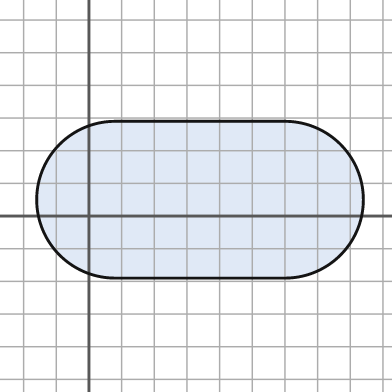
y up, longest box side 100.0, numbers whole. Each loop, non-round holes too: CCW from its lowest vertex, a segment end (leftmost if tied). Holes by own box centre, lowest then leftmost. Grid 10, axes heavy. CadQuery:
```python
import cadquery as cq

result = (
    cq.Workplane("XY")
    .moveTo(8.0, -19.0)
    .lineTo(60.0, -19.0)
    .threePointArc((84.0, 5.0), (60.0, 29.0))
    .lineTo(8.0, 29.0)
    .threePointArc((-16.0, 5.0), (8.0, -19.0))
    .close()
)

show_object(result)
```